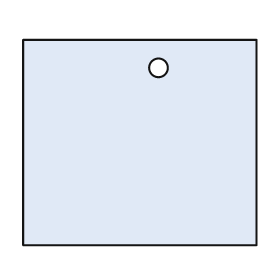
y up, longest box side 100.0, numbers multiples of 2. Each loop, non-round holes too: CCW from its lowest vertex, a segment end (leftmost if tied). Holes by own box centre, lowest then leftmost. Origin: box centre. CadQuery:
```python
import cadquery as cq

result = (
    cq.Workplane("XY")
    .moveTo(-50.0, -44.0)
    .lineTo(50.0, -44.0)
    .lineTo(50.0, 44.0)
    .lineTo(-50.0, 44.0)
    .close()
    .moveTo(8.0, 32.0)
    .circle(4.0)
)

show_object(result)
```